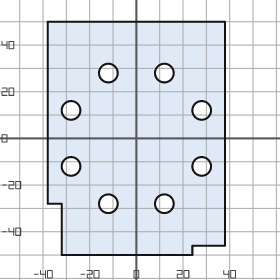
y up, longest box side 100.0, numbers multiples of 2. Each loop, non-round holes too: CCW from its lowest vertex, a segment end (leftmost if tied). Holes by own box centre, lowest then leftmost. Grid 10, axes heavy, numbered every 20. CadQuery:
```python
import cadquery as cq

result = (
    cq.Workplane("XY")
    .moveTo(-32.0, -50.0)
    .lineTo(24.0, -50.0)
    .lineTo(24.0, -46.0)
    .lineTo(38.0, -46.0)
    .lineTo(38.0, 50.0)
    .lineTo(-38.0, 50.0)
    .lineTo(-38.0, -28.0)
    .lineTo(-32.0, -28.0)
    .close()
    .moveTo(-12.0, -28.0)
    .circle(4.0)
    .moveTo(12.0, -28.0)
    .circle(4.0)
    .moveTo(-28.0, -12.0)
    .circle(4.0)
    .moveTo(28.0, -12.0)
    .circle(4.0)
    .moveTo(-28.0, 12.0)
    .circle(4.0)
    .moveTo(28.0, 12.0)
    .circle(4.0)
    .moveTo(-12.0, 28.0)
    .circle(4.0)
    .moveTo(12.0, 28.0)
    .circle(4.0)
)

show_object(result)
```